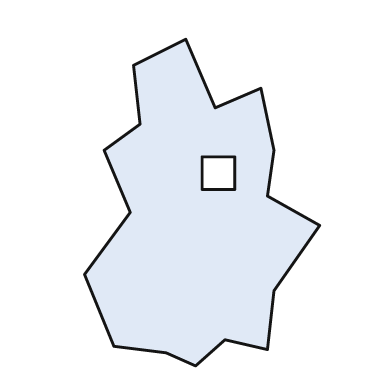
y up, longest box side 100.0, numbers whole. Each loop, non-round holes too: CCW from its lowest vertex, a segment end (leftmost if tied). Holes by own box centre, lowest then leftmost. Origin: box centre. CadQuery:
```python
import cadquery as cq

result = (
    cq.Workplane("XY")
    .moveTo(-2.0, -50.0)
    .lineTo(7.0, -42.0)
    .lineTo(20.0, -45.0)
    .lineTo(22.0, -27.0)
    .lineTo(36.0, -7.0)
    .lineTo(20.0, 2.0)
    .lineTo(22.0, 16.0)
    .lineTo(18.0, 35.0)
    .lineTo(4.0, 29.0)
    .lineTo(-5.0, 50.0)
    .lineTo(-21.0, 42.0)
    .lineTo(-19.0, 24.0)
    .lineTo(-30.0, 16.0)
    .lineTo(-22.0, -3.0)
    .lineTo(-36.0, -22.0)
    .lineTo(-27.0, -44.0)
    .lineTo(-11.0, -46.0)
    .close()
    .moveTo(0.0, 4.0)
    .lineTo(10.0, 4.0)
    .lineTo(10.0, 14.0)
    .lineTo(0.0, 14.0)
    .close()
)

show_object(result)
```